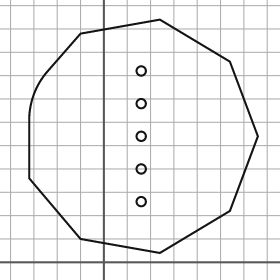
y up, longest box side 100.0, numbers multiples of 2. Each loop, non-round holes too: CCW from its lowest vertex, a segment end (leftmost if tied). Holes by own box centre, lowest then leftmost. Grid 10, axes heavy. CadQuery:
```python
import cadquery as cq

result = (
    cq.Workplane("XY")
    .moveTo(24.0, 4.0)
    .lineTo(54.0, 22.0)
    .lineTo(66.0, 54.0)
    .lineTo(54.0, 86.0)
    .lineTo(24.0, 104.0)
    .lineTo(-10.0, 98.0)
    .lineTo(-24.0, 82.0)
    .threePointArc((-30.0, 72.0), (-32.0, 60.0))
    .lineTo(-32.0, 36.0)
    .lineTo(-10.0, 10.0)
    .close()
    .moveTo(16.0, 26.0)
    .circle(2.0)
    .moveTo(16.0, 40.0)
    .circle(2.0)
    .moveTo(16.0, 54.0)
    .circle(2.0)
    .moveTo(16.0, 68.0)
    .circle(2.0)
    .moveTo(16.0, 82.0)
    .circle(2.0)
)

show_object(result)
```